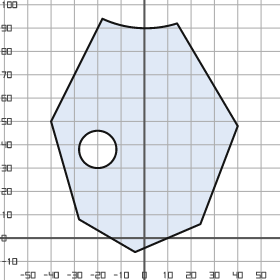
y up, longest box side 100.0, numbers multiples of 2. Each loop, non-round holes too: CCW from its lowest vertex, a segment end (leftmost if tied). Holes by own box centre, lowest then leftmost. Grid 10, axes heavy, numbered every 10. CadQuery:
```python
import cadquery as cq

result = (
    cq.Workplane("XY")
    .moveTo(-4.0, -6.0)
    .lineTo(24.0, 6.0)
    .lineTo(40.0, 48.0)
    .lineTo(14.0, 92.0)
    .threePointArc((-2.0, 90.0), (-18.0, 94.0))
    .lineTo(-40.0, 50.0)
    .lineTo(-28.0, 8.0)
    .close()
    .moveTo(-20.0, 38.0)
    .circle(8.0)
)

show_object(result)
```